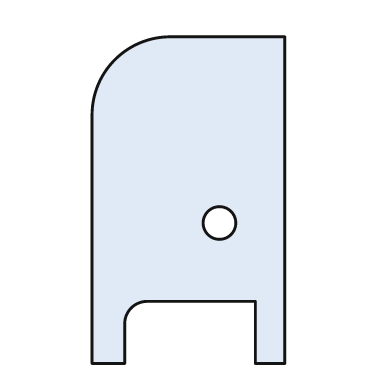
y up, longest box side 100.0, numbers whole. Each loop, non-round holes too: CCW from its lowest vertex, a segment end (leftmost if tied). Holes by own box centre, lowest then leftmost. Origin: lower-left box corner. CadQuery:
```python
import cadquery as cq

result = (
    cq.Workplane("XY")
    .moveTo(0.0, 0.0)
    .lineTo(10.0, 0.0)
    .lineTo(10.0, 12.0)
    .threePointArc((12.0, 17.0), (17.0, 19.0))
    .lineTo(50.0, 19.0)
    .lineTo(50.0, 0.0)
    .lineTo(59.0, 0.0)
    .lineTo(59.0, 100.0)
    .lineTo(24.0, 100.0)
    .threePointArc((7.0, 93.0), (0.0, 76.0))
    .close()
    .moveTo(39.0, 43.0)
    .circle(5.0)
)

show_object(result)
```